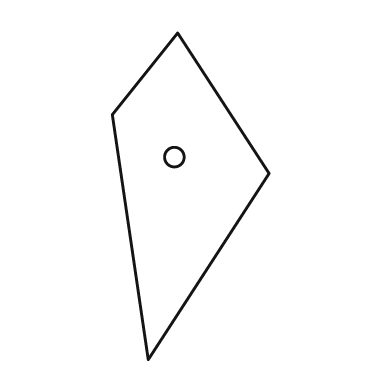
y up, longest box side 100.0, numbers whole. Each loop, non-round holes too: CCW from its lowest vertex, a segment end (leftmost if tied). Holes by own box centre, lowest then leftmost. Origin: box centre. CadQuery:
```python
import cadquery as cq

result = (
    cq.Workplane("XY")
    .moveTo(-13.0, -50.0)
    .lineTo(24.0, 7.0)
    .lineTo(-4.0, 50.0)
    .lineTo(-24.0, 25.0)
    .close()
    .moveTo(-5.0, 12.0)
    .circle(3.0)
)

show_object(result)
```